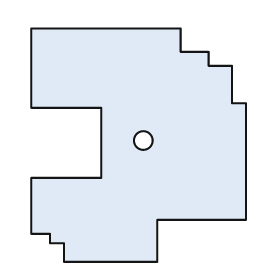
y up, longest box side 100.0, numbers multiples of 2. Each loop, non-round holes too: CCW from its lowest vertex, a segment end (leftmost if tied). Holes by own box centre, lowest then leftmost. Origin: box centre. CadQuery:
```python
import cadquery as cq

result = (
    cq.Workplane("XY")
    .moveTo(-32.0, -50.0)
    .lineTo(8.0, -50.0)
    .lineTo(8.0, -32.0)
    .lineTo(46.0, -32.0)
    .lineTo(46.0, 18.0)
    .lineTo(40.0, 18.0)
    .lineTo(40.0, 34.0)
    .lineTo(30.0, 34.0)
    .lineTo(30.0, 40.0)
    .lineTo(18.0, 40.0)
    .lineTo(18.0, 50.0)
    .lineTo(-46.0, 50.0)
    .lineTo(-46.0, 16.0)
    .lineTo(-16.0, 16.0)
    .lineTo(-16.0, -14.0)
    .lineTo(-46.0, -14.0)
    .lineTo(-46.0, -38.0)
    .lineTo(-38.0, -38.0)
    .lineTo(-38.0, -42.0)
    .lineTo(-32.0, -42.0)
    .close()
    .moveTo(2.0, 2.0)
    .circle(4.0)
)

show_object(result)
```